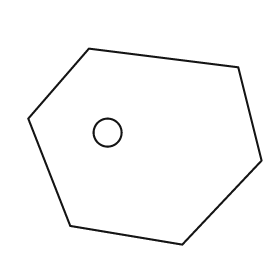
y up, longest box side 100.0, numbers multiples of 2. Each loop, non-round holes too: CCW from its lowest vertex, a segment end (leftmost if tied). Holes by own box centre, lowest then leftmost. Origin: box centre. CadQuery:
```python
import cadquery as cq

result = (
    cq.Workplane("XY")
    .moveTo(16.0, -42.0)
    .lineTo(50.0, -6.0)
    .lineTo(40.0, 34.0)
    .lineTo(-24.0, 42.0)
    .lineTo(-50.0, 12.0)
    .lineTo(-32.0, -34.0)
    .close()
    .moveTo(-16.0, 6.0)
    .circle(6.0)
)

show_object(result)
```